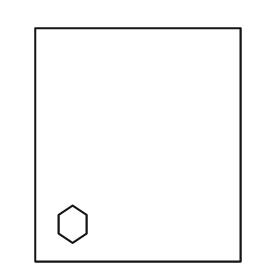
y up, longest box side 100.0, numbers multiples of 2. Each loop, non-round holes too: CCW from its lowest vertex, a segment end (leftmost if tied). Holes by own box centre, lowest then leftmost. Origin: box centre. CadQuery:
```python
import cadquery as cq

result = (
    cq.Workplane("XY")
    .moveTo(-44.0, -50.0)
    .lineTo(44.0, -50.0)
    .lineTo(44.0, 50.0)
    .lineTo(-44.0, 50.0)
    .close()
    .moveTo(-28.0, -42.0)
    .lineTo(-22.0, -38.0)
    .lineTo(-22.0, -30.0)
    .lineTo(-28.0, -26.0)
    .lineTo(-34.0, -30.0)
    .lineTo(-34.0, -38.0)
    .close()
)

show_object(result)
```